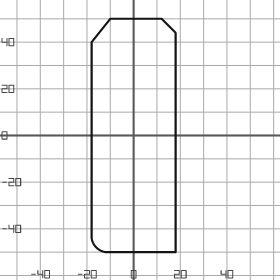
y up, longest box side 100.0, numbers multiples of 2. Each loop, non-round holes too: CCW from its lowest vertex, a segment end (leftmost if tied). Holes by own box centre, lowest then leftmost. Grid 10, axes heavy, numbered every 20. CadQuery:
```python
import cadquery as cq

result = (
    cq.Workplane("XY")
    .moveTo(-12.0, -50.0)
    .lineTo(18.0, -50.0)
    .lineTo(18.0, 44.0)
    .lineTo(12.0, 50.0)
    .lineTo(-10.0, 50.0)
    .lineTo(-18.0, 40.0)
    .lineTo(-18.0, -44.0)
    .threePointArc((-16.0, -48.0), (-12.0, -50.0))
    .close()
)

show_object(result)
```